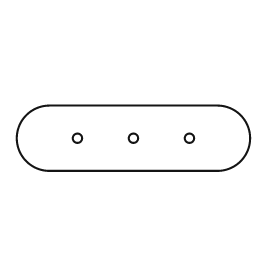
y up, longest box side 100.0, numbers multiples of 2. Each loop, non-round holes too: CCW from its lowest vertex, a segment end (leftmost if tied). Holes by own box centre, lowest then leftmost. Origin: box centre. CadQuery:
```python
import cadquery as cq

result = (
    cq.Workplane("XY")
    .moveTo(-36.0, -14.0)
    .lineTo(36.0, -14.0)
    .threePointArc((50.0, 0.0), (36.0, 14.0))
    .lineTo(-36.0, 14.0)
    .threePointArc((-50.0, 0.0), (-36.0, -14.0))
    .close()
    .moveTo(-24.0, 0.0)
    .circle(2.0)
    .moveTo(0.0, 0.0)
    .circle(2.0)
    .moveTo(24.0, 0.0)
    .circle(2.0)
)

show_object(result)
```